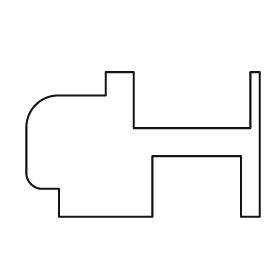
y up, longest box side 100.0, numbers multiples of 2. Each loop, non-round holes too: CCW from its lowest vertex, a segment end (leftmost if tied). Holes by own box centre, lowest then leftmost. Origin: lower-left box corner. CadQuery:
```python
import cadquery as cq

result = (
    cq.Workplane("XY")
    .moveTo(14.0, 0.0)
    .lineTo(54.0, 0.0)
    .lineTo(54.0, 26.0)
    .lineTo(92.0, 26.0)
    .lineTo(92.0, 0.0)
    .lineTo(100.0, 0.0)
    .lineTo(100.0, 62.0)
    .lineTo(96.0, 62.0)
    .lineTo(96.0, 38.0)
    .lineTo(46.0, 38.0)
    .lineTo(46.0, 62.0)
    .lineTo(34.0, 62.0)
    .lineTo(34.0, 52.0)
    .lineTo(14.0, 52.0)
    .threePointArc((4.0, 48.0), (0.0, 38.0))
    .lineTo(0.0, 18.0)
    .threePointArc((2.0, 14.0), (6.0, 12.0))
    .lineTo(14.0, 12.0)
    .close()
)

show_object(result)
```